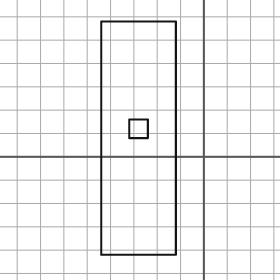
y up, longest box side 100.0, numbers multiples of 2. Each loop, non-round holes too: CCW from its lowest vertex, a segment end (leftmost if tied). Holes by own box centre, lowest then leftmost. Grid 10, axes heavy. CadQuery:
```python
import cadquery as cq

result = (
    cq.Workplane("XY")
    .moveTo(-44.0, -42.0)
    .lineTo(-12.0, -42.0)
    .lineTo(-12.0, 58.0)
    .lineTo(-44.0, 58.0)
    .close()
    .moveTo(-32.0, 8.0)
    .lineTo(-24.0, 8.0)
    .lineTo(-24.0, 16.0)
    .lineTo(-32.0, 16.0)
    .close()
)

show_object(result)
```